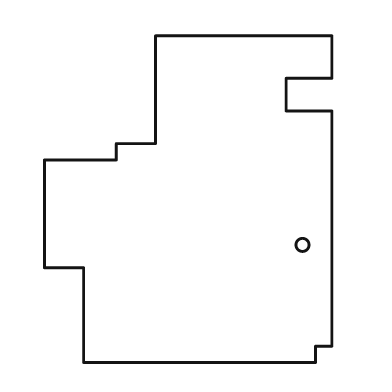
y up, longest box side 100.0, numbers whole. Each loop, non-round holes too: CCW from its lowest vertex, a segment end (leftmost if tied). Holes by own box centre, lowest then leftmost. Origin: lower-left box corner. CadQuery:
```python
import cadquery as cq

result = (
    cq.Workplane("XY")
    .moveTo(12.0, 0.0)
    .lineTo(83.0, 0.0)
    .lineTo(83.0, 5.0)
    .lineTo(88.0, 5.0)
    .lineTo(88.0, 77.0)
    .lineTo(74.0, 77.0)
    .lineTo(74.0, 87.0)
    .lineTo(88.0, 87.0)
    .lineTo(88.0, 100.0)
    .lineTo(34.0, 100.0)
    .lineTo(34.0, 67.0)
    .lineTo(22.0, 67.0)
    .lineTo(22.0, 62.0)
    .lineTo(0.0, 62.0)
    .lineTo(0.0, 29.0)
    .lineTo(12.0, 29.0)
    .close()
    .moveTo(79.0, 36.0)
    .circle(2.0)
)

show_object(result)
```